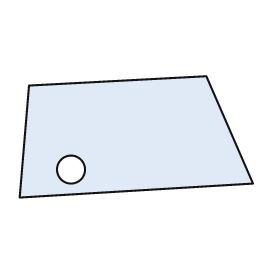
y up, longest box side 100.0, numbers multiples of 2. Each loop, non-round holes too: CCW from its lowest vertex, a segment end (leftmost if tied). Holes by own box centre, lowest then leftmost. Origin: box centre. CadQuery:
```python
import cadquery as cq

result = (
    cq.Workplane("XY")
    .moveTo(-50.0, -26.0)
    .lineTo(50.0, -20.0)
    .lineTo(30.0, 26.0)
    .lineTo(-46.0, 22.0)
    .close()
    .moveTo(-28.0, -14.0)
    .circle(6.0)
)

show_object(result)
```